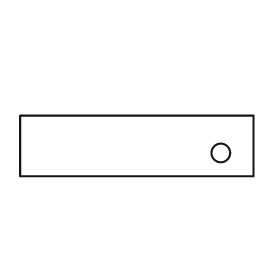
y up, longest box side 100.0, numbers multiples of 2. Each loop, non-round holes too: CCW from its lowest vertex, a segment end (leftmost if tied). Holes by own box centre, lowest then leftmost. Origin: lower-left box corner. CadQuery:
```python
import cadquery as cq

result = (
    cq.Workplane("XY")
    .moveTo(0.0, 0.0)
    .lineTo(100.0, 0.0)
    .lineTo(100.0, 26.0)
    .lineTo(0.0, 26.0)
    .close()
    .moveTo(86.0, 10.0)
    .circle(4.0)
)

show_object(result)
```